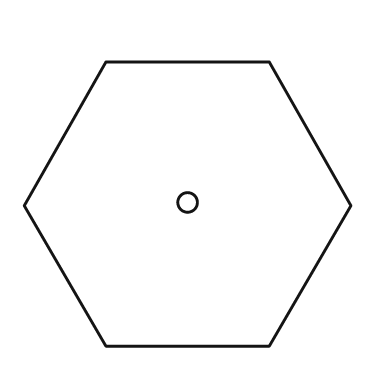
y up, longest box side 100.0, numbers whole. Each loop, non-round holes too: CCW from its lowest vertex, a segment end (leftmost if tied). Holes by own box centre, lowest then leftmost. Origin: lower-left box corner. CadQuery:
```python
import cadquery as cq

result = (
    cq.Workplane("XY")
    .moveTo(25.0, 0.0)
    .lineTo(75.0, 0.0)
    .lineTo(100.0, 43.0)
    .lineTo(75.0, 87.0)
    .lineTo(25.0, 87.0)
    .lineTo(0.0, 43.0)
    .close()
    .moveTo(50.0, 44.0)
    .circle(3.0)
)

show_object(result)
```